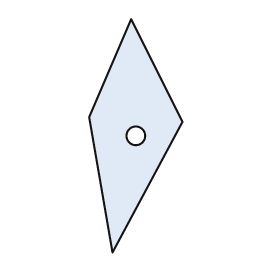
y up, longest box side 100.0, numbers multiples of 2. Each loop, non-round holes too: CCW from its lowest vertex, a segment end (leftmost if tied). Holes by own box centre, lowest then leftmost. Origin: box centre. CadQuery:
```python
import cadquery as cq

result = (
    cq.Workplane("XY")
    .moveTo(-10.0, -50.0)
    .lineTo(20.0, 6.0)
    .lineTo(-2.0, 50.0)
    .lineTo(-20.0, 8.0)
    .close()
    .moveTo(0.0, 0.0)
    .circle(4.0)
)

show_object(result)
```